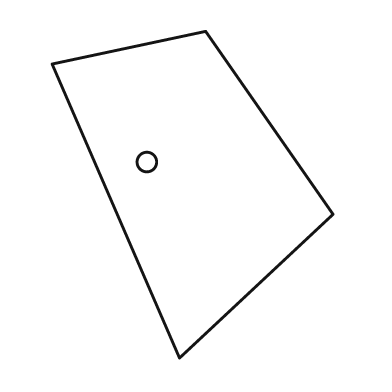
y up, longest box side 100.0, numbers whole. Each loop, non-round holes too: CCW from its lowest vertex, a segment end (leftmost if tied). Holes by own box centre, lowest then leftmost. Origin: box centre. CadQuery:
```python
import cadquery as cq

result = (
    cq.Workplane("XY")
    .moveTo(-4.0, -50.0)
    .lineTo(43.0, -6.0)
    .lineTo(4.0, 50.0)
    .lineTo(-43.0, 40.0)
    .close()
    .moveTo(-14.0, 10.0)
    .circle(3.0)
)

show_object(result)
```